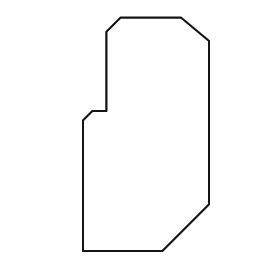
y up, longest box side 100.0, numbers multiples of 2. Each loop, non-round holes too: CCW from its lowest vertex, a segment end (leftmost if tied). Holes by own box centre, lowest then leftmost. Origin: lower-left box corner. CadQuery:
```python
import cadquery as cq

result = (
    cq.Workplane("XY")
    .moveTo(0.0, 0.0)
    .lineTo(34.0, 0.0)
    .lineTo(54.0, 20.0)
    .lineTo(54.0, 90.0)
    .lineTo(42.0, 100.0)
    .lineTo(16.0, 100.0)
    .lineTo(10.0, 94.0)
    .lineTo(10.0, 60.0)
    .lineTo(4.0, 60.0)
    .lineTo(0.0, 56.0)
    .close()
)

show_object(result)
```